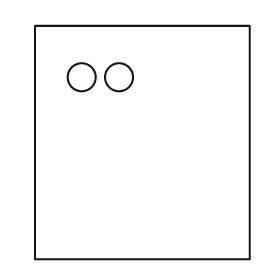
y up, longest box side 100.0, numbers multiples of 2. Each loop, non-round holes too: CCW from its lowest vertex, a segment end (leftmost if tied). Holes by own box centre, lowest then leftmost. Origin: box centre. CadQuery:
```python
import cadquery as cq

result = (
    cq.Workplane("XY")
    .moveTo(-46.0, -50.0)
    .lineTo(46.0, -50.0)
    .lineTo(46.0, 50.0)
    .lineTo(-46.0, 50.0)
    .close()
    .moveTo(-26.0, 28.0)
    .circle(6.0)
    .moveTo(-10.0, 28.0)
    .circle(6.0)
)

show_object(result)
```